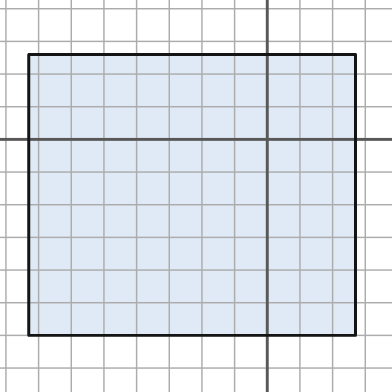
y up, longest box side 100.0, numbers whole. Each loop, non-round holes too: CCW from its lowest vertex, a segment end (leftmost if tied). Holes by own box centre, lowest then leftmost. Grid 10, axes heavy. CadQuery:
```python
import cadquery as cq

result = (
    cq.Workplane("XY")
    .moveTo(-73.0, -60.0)
    .lineTo(27.0, -60.0)
    .lineTo(27.0, 26.0)
    .lineTo(-73.0, 26.0)
    .close()
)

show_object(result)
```